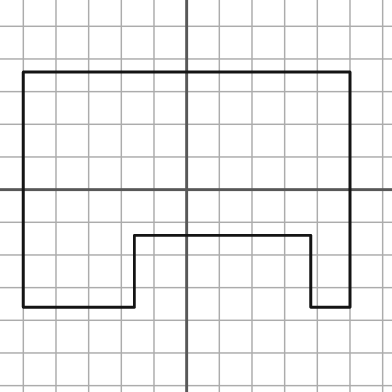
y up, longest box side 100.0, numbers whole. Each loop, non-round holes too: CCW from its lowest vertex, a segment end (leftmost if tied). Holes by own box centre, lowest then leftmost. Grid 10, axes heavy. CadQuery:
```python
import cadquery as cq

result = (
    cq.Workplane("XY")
    .moveTo(-50.0, -36.0)
    .lineTo(-16.0, -36.0)
    .lineTo(-16.0, -14.0)
    .lineTo(38.0, -14.0)
    .lineTo(38.0, -36.0)
    .lineTo(50.0, -36.0)
    .lineTo(50.0, 36.0)
    .lineTo(-50.0, 36.0)
    .close()
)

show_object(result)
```